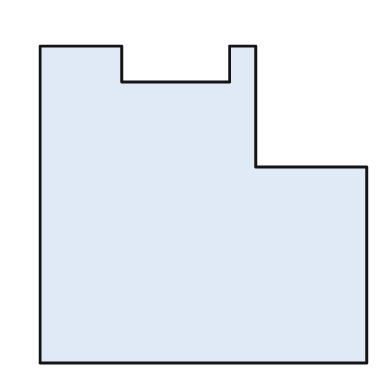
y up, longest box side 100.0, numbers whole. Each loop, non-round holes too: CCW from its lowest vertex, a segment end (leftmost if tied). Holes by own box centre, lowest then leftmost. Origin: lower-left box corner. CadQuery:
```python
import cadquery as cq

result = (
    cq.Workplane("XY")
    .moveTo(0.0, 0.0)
    .lineTo(100.0, 0.0)
    .lineTo(100.0, 60.0)
    .lineTo(66.0, 60.0)
    .lineTo(66.0, 97.0)
    .lineTo(58.0, 97.0)
    .lineTo(58.0, 86.0)
    .lineTo(25.0, 86.0)
    .lineTo(25.0, 97.0)
    .lineTo(0.0, 97.0)
    .close()
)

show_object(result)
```